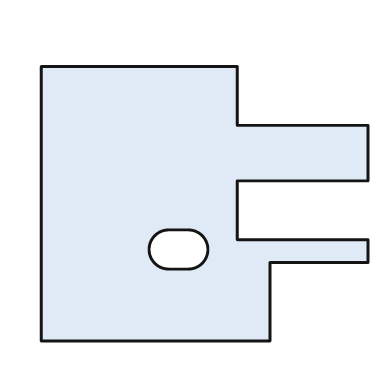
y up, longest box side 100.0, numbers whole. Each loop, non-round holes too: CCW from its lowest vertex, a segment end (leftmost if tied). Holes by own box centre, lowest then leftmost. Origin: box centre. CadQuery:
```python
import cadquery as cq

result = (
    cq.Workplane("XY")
    .moveTo(-50.0, -42.0)
    .lineTo(20.0, -42.0)
    .lineTo(20.0, -18.0)
    .lineTo(50.0, -18.0)
    .lineTo(50.0, -11.0)
    .lineTo(10.0, -11.0)
    .lineTo(10.0, 7.0)
    .lineTo(50.0, 7.0)
    .lineTo(50.0, 24.0)
    .lineTo(10.0, 24.0)
    .lineTo(10.0, 42.0)
    .lineTo(-50.0, 42.0)
    .close()
    .moveTo(-11.0, -20.0)
    .lineTo(-5.0, -20.0)
    .threePointArc((1.0, -14.0), (-5.0, -8.0))
    .lineTo(-11.0, -8.0)
    .threePointArc((-17.0, -14.0), (-11.0, -20.0))
    .close()
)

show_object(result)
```